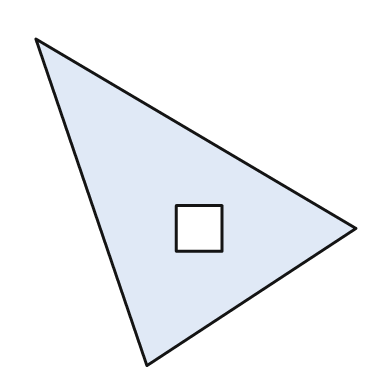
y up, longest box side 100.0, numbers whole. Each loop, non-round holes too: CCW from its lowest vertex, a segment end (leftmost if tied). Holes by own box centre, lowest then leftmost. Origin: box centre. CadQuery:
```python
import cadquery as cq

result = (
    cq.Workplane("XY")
    .moveTo(-15.0, -50.0)
    .lineTo(49.0, -8.0)
    .lineTo(-49.0, 50.0)
    .close()
    .moveTo(-6.0, -15.0)
    .lineTo(8.0, -15.0)
    .lineTo(8.0, -1.0)
    .lineTo(-6.0, -1.0)
    .close()
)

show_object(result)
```